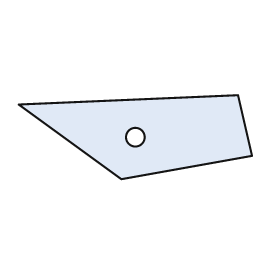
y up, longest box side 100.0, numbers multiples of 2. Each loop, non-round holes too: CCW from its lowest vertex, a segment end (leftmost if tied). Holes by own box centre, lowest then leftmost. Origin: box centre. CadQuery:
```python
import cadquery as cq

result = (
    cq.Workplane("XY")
    .moveTo(-6.0, -18.0)
    .lineTo(50.0, -8.0)
    .lineTo(44.0, 18.0)
    .lineTo(-50.0, 14.0)
    .close()
    .moveTo(0.0, 0.0)
    .circle(4.0)
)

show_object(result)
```